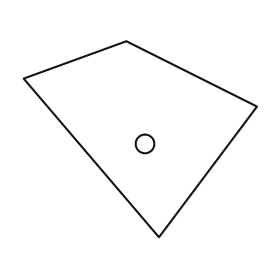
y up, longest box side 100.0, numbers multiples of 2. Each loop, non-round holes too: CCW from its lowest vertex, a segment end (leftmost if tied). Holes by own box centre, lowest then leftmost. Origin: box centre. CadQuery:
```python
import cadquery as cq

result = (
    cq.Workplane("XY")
    .moveTo(8.0, -42.0)
    .lineTo(50.0, 14.0)
    .lineTo(-6.0, 42.0)
    .lineTo(-50.0, 26.0)
    .close()
    .moveTo(2.0, -2.0)
    .circle(4.0)
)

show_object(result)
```